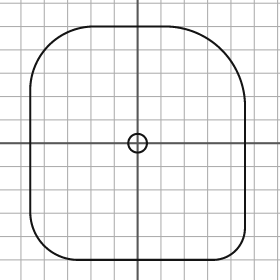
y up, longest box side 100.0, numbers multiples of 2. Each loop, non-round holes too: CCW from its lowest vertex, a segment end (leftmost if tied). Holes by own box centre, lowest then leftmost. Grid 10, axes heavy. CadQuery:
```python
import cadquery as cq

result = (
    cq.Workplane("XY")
    .moveTo(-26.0, -50.0)
    .lineTo(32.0, -50.0)
    .threePointArc((42.0, -46.0), (46.0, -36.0))
    .lineTo(46.0, 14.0)
    .threePointArc((36.0, 40.0), (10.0, 50.0))
    .lineTo(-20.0, 50.0)
    .threePointArc((-38.0, 42.0), (-46.0, 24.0))
    .lineTo(-46.0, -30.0)
    .threePointArc((-40.0, -44.0), (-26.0, -50.0))
    .close()
    .moveTo(0.0, 0.0)
    .circle(4.0)
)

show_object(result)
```